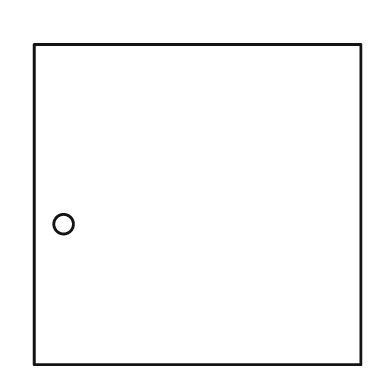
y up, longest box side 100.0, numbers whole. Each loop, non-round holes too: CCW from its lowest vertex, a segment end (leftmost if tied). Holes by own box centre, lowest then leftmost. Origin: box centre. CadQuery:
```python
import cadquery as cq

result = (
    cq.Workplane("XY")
    .moveTo(-50.0, -49.0)
    .lineTo(50.0, -49.0)
    .lineTo(50.0, 49.0)
    .lineTo(-50.0, 49.0)
    .close()
    .moveTo(-41.0, -6.0)
    .circle(3.0)
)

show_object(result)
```